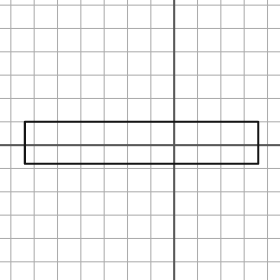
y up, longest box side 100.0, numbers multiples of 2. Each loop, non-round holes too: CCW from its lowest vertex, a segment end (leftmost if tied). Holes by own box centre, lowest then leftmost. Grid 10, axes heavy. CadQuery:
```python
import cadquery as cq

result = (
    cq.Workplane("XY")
    .moveTo(-64.0, -8.0)
    .lineTo(36.0, -8.0)
    .lineTo(36.0, 10.0)
    .lineTo(-64.0, 10.0)
    .close()
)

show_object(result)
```